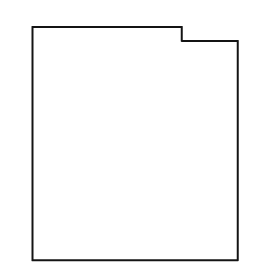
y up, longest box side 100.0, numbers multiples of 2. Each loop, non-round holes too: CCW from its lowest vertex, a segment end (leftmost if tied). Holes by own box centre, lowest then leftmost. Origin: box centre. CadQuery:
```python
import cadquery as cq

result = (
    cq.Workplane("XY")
    .moveTo(-44.0, -50.0)
    .lineTo(44.0, -50.0)
    .lineTo(44.0, 44.0)
    .lineTo(20.0, 44.0)
    .lineTo(20.0, 50.0)
    .lineTo(-44.0, 50.0)
    .close()
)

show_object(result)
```